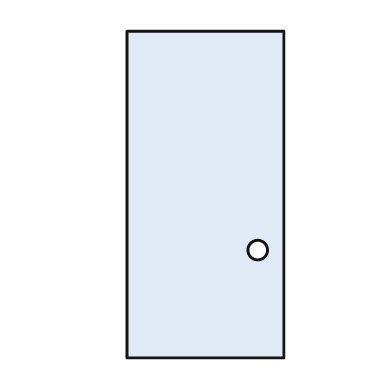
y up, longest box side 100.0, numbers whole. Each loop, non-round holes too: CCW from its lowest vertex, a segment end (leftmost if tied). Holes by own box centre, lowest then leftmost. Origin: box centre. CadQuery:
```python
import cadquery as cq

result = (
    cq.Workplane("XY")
    .moveTo(-24.0, -50.0)
    .lineTo(24.0, -50.0)
    .lineTo(24.0, 50.0)
    .lineTo(-24.0, 50.0)
    .close()
    .moveTo(16.0, -17.0)
    .circle(3.0)
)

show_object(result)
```